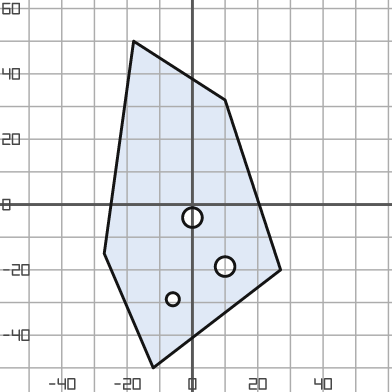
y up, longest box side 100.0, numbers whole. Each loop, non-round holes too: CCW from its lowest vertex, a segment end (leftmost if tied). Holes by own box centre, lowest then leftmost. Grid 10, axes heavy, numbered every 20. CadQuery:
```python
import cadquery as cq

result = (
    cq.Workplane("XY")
    .moveTo(-12.0, -50.0)
    .lineTo(27.0, -20.0)
    .lineTo(10.0, 32.0)
    .lineTo(-18.0, 50.0)
    .lineTo(-27.0, -15.0)
    .close()
    .moveTo(-6.0, -29.0)
    .circle(2.0)
    .moveTo(10.0, -19.0)
    .circle(3.0)
    .moveTo(0.0, -4.0)
    .circle(3.0)
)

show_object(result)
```